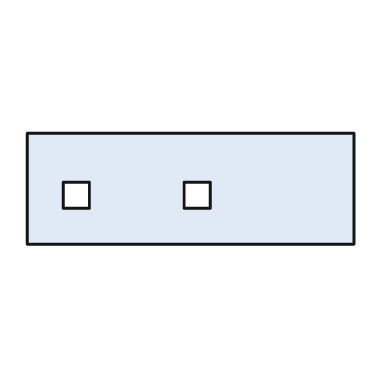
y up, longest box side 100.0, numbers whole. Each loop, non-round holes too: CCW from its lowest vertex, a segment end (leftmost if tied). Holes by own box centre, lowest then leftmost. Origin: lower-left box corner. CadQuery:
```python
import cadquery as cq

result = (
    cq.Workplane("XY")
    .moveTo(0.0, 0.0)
    .lineTo(100.0, 0.0)
    .lineTo(100.0, 34.0)
    .lineTo(0.0, 34.0)
    .close()
    .moveTo(11.0, 11.0)
    .lineTo(19.0, 11.0)
    .lineTo(19.0, 19.0)
    .lineTo(11.0, 19.0)
    .close()
    .moveTo(48.0, 11.0)
    .lineTo(56.0, 11.0)
    .lineTo(56.0, 19.0)
    .lineTo(48.0, 19.0)
    .close()
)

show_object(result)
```